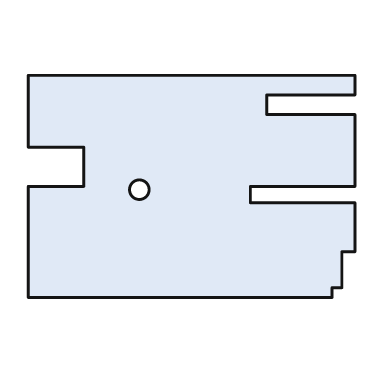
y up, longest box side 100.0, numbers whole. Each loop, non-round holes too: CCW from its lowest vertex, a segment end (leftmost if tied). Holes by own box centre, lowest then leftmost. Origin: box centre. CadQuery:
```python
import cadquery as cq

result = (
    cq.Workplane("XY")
    .moveTo(-50.0, -34.0)
    .lineTo(43.0, -34.0)
    .lineTo(43.0, -31.0)
    .lineTo(46.0, -31.0)
    .lineTo(46.0, -20.0)
    .lineTo(50.0, -20.0)
    .lineTo(50.0, -5.0)
    .lineTo(18.0, -5.0)
    .lineTo(18.0, 0.0)
    .lineTo(50.0, 0.0)
    .lineTo(50.0, 22.0)
    .lineTo(23.0, 22.0)
    .lineTo(23.0, 28.0)
    .lineTo(50.0, 28.0)
    .lineTo(50.0, 34.0)
    .lineTo(-50.0, 34.0)
    .lineTo(-50.0, 12.0)
    .lineTo(-33.0, 12.0)
    .lineTo(-33.0, 0.0)
    .lineTo(-50.0, 0.0)
    .close()
    .moveTo(-16.0, -1.0)
    .circle(3.0)
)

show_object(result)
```